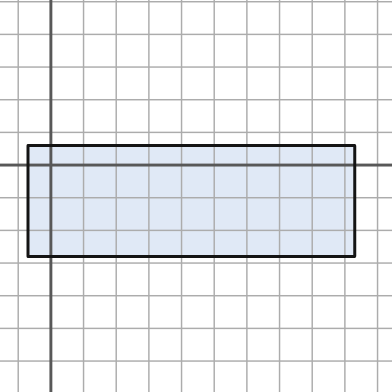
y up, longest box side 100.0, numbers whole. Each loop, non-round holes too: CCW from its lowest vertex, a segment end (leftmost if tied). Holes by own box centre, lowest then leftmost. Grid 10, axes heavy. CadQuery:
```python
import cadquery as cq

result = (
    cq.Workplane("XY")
    .moveTo(-7.0, -28.0)
    .lineTo(93.0, -28.0)
    .lineTo(93.0, 6.0)
    .lineTo(-7.0, 6.0)
    .close()
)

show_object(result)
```